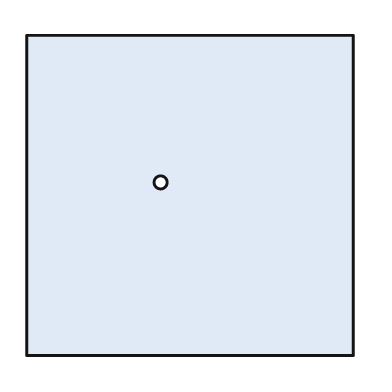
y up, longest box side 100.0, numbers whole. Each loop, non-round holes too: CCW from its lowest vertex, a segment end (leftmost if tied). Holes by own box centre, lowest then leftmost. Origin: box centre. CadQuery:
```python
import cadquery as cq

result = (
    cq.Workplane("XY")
    .moveTo(-50.0, -49.0)
    .lineTo(50.0, -49.0)
    .lineTo(50.0, 49.0)
    .lineTo(-50.0, 49.0)
    .close()
    .moveTo(-9.0, 4.0)
    .circle(2.0)
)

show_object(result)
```